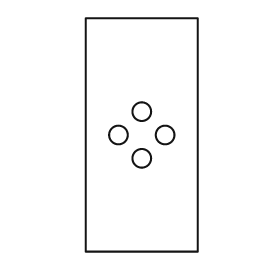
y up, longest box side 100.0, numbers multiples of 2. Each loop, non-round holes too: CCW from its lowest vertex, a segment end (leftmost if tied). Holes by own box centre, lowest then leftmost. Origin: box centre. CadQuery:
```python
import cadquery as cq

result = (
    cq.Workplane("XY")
    .moveTo(-24.0, -50.0)
    .lineTo(24.0, -50.0)
    .lineTo(24.0, 50.0)
    .lineTo(-24.0, 50.0)
    .close()
    .moveTo(0.0, -10.0)
    .circle(4.0)
    .moveTo(-10.0, 0.0)
    .circle(4.0)
    .moveTo(10.0, 0.0)
    .circle(4.0)
    .moveTo(0.0, 10.0)
    .circle(4.0)
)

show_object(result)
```